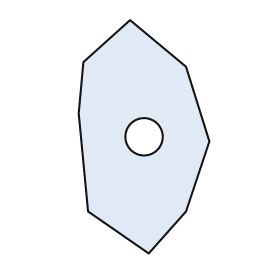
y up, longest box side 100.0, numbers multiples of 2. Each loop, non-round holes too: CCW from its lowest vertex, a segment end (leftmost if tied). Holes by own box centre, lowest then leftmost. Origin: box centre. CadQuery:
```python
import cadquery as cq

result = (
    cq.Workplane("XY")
    .moveTo(2.0, -50.0)
    .lineTo(18.0, -32.0)
    .lineTo(28.0, -2.0)
    .lineTo(18.0, 30.0)
    .lineTo(-6.0, 50.0)
    .lineTo(-26.0, 32.0)
    .lineTo(-28.0, 10.0)
    .lineTo(-24.0, -32.0)
    .close()
    .moveTo(0.0, 0.0)
    .circle(8.0)
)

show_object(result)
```